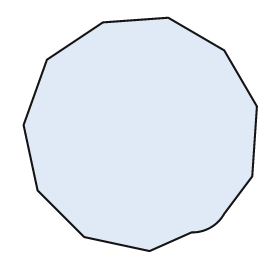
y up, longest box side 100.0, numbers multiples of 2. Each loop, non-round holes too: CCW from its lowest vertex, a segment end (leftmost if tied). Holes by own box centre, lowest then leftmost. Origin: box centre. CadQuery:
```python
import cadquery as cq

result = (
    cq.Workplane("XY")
    .moveTo(4.0, -50.0)
    .lineTo(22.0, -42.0)
    .threePointArc((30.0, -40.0), (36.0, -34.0))
    .lineTo(48.0, -18.0)
    .lineTo(50.0, 12.0)
    .lineTo(36.0, 36.0)
    .lineTo(12.0, 50.0)
    .lineTo(-16.0, 48.0)
    .lineTo(-40.0, 32.0)
    .lineTo(-50.0, 4.0)
    .lineTo(-44.0, -24.0)
    .lineTo(-24.0, -44.0)
    .close()
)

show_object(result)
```